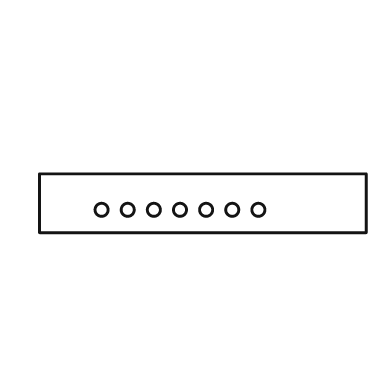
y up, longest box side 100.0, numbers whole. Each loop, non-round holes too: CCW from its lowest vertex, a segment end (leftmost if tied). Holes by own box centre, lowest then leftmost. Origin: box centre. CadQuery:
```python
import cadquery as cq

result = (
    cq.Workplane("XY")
    .moveTo(-50.0, -9.0)
    .lineTo(50.0, -9.0)
    .lineTo(50.0, 9.0)
    .lineTo(-50.0, 9.0)
    .close()
    .moveTo(-31.0, -2.0)
    .circle(2.0)
    .moveTo(-23.0, -2.0)
    .circle(2.0)
    .moveTo(-15.0, -2.0)
    .circle(2.0)
    .moveTo(-7.0, -2.0)
    .circle(2.0)
    .moveTo(1.0, -2.0)
    .circle(2.0)
    .moveTo(9.0, -2.0)
    .circle(2.0)
    .moveTo(17.0, -2.0)
    .circle(2.0)
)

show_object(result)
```